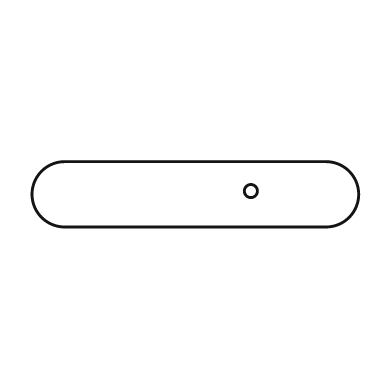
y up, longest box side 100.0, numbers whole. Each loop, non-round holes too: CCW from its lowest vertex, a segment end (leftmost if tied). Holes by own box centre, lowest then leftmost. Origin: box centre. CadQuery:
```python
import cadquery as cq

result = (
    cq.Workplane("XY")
    .moveTo(-40.0, -10.0)
    .lineTo(40.0, -10.0)
    .threePointArc((50.0, 0.0), (40.0, 10.0))
    .lineTo(-40.0, 10.0)
    .threePointArc((-50.0, 0.0), (-40.0, -10.0))
    .close()
    .moveTo(17.0, 1.0)
    .circle(2.0)
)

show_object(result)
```